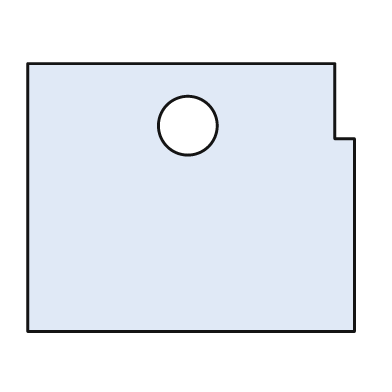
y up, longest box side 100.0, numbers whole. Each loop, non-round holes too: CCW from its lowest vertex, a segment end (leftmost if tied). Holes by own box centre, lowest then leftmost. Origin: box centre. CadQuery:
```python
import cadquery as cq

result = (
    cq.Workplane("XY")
    .moveTo(-50.0, -41.0)
    .lineTo(50.0, -41.0)
    .lineTo(50.0, 18.0)
    .lineTo(44.0, 18.0)
    .lineTo(44.0, 41.0)
    .lineTo(-50.0, 41.0)
    .close()
    .moveTo(-1.0, 22.0)
    .circle(9.0)
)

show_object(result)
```